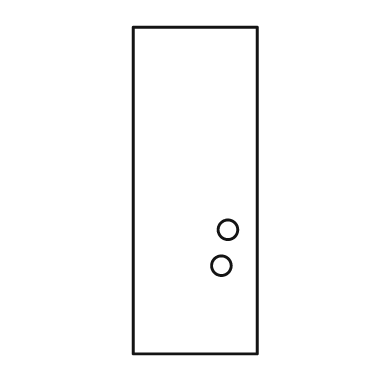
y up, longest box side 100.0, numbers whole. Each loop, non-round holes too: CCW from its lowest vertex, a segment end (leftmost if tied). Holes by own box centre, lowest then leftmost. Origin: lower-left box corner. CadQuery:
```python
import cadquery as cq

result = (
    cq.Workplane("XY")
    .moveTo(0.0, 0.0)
    .lineTo(38.0, 0.0)
    .lineTo(38.0, 100.0)
    .lineTo(0.0, 100.0)
    .close()
    .moveTo(27.0, 27.0)
    .circle(3.0)
    .moveTo(29.0, 38.0)
    .circle(3.0)
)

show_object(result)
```